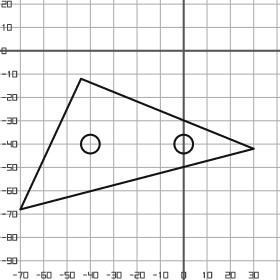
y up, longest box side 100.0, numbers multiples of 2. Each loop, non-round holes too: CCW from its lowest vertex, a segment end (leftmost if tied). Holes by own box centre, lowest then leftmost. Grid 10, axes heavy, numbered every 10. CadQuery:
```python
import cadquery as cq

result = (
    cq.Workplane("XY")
    .moveTo(-70.0, -68.0)
    .lineTo(30.0, -42.0)
    .lineTo(-44.0, -12.0)
    .close()
    .moveTo(-40.0, -40.0)
    .circle(4.0)
    .moveTo(0.0, -40.0)
    .circle(4.0)
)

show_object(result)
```